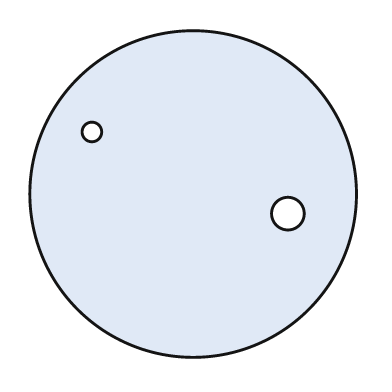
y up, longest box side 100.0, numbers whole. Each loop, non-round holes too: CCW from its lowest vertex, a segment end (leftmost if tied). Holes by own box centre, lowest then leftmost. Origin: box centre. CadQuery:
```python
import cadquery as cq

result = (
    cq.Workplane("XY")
    .moveTo(0.0, 0.0)
    .circle(50.0)
    .moveTo(29.0, -6.0)
    .circle(5.0)
    .moveTo(-31.0, 19.0)
    .circle(3.0)
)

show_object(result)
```